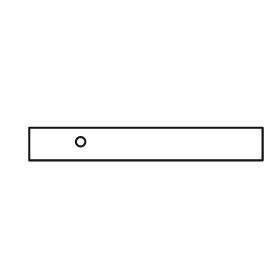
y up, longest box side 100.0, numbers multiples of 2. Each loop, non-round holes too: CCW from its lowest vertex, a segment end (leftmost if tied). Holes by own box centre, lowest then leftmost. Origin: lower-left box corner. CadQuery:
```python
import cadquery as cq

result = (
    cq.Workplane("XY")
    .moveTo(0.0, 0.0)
    .lineTo(100.0, 0.0)
    .lineTo(100.0, 14.0)
    .lineTo(0.0, 14.0)
    .close()
    .moveTo(22.0, 8.0)
    .circle(2.0)
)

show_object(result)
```